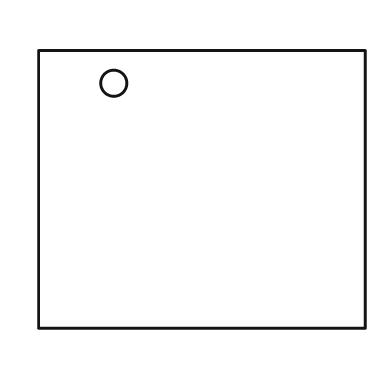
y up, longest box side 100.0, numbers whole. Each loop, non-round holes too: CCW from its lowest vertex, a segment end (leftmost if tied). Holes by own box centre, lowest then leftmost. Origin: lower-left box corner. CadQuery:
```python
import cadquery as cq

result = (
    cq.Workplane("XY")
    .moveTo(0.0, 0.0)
    .lineTo(100.0, 0.0)
    .lineTo(100.0, 85.0)
    .lineTo(0.0, 85.0)
    .close()
    .moveTo(23.0, 75.0)
    .circle(4.0)
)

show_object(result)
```